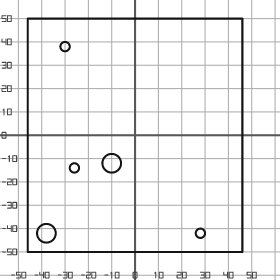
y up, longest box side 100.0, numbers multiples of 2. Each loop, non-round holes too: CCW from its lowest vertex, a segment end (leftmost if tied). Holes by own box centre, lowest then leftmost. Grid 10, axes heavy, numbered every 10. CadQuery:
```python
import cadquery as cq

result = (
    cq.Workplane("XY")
    .moveTo(-46.0, -50.0)
    .lineTo(46.0, -50.0)
    .lineTo(46.0, 50.0)
    .lineTo(-46.0, 50.0)
    .close()
    .moveTo(-38.0, -42.0)
    .circle(4.0)
    .moveTo(28.0, -42.0)
    .circle(2.0)
    .moveTo(-26.0, -14.0)
    .circle(2.0)
    .moveTo(-10.0, -12.0)
    .circle(4.0)
    .moveTo(-30.0, 38.0)
    .circle(2.0)
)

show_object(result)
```